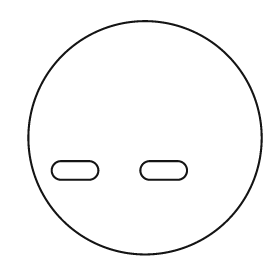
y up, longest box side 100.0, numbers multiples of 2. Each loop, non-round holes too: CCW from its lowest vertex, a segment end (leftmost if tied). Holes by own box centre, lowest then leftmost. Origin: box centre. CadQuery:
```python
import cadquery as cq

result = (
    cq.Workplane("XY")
    .moveTo(0.0, 0.0)
    .circle(50.0)
    .moveTo(-36.0, -18.0)
    .lineTo(-24.0, -18.0)
    .threePointArc((-20.0, -14.0), (-24.0, -10.0))
    .lineTo(-36.0, -10.0)
    .threePointArc((-40.0, -14.0), (-36.0, -18.0))
    .close()
    .moveTo(2.0, -18.0)
    .lineTo(14.0, -18.0)
    .threePointArc((18.0, -14.0), (14.0, -10.0))
    .lineTo(2.0, -10.0)
    .threePointArc((-2.0, -14.0), (2.0, -18.0))
    .close()
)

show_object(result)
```